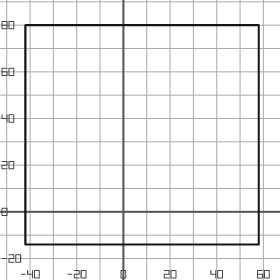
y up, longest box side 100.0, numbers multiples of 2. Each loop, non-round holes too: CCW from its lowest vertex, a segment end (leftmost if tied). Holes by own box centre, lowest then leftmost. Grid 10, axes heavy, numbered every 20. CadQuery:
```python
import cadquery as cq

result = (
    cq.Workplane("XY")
    .moveTo(-42.0, -14.0)
    .lineTo(58.0, -14.0)
    .lineTo(58.0, 80.0)
    .lineTo(-42.0, 80.0)
    .close()
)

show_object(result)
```